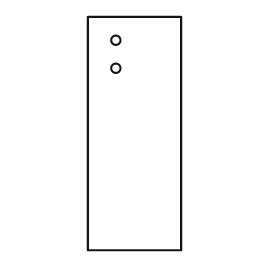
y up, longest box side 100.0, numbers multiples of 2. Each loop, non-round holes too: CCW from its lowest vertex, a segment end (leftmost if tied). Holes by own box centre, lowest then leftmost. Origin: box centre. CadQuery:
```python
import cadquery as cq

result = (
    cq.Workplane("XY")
    .moveTo(-20.0, -50.0)
    .lineTo(20.0, -50.0)
    .lineTo(20.0, 50.0)
    .lineTo(-20.0, 50.0)
    .close()
    .moveTo(-8.0, 28.0)
    .circle(2.0)
    .moveTo(-8.0, 40.0)
    .circle(2.0)
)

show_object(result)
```